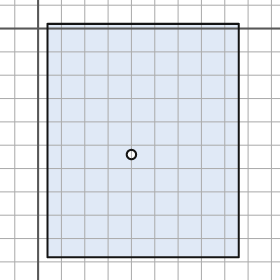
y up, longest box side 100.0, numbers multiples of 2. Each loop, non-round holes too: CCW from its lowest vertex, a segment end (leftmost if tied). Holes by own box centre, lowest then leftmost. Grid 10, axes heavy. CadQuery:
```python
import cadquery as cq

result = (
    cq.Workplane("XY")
    .moveTo(4.0, -98.0)
    .lineTo(86.0, -98.0)
    .lineTo(86.0, 2.0)
    .lineTo(4.0, 2.0)
    .close()
    .moveTo(40.0, -54.0)
    .circle(2.0)
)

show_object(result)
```